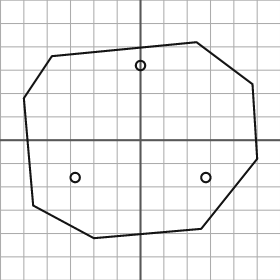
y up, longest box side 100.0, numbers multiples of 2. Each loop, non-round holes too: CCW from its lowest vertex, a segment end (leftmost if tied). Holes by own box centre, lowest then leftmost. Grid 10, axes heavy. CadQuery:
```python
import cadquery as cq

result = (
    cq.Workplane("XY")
    .moveTo(-20.0, -42.0)
    .lineTo(26.0, -38.0)
    .lineTo(50.0, -8.0)
    .lineTo(48.0, 24.0)
    .lineTo(24.0, 42.0)
    .lineTo(-38.0, 36.0)
    .lineTo(-50.0, 18.0)
    .lineTo(-46.0, -28.0)
    .close()
    .moveTo(-28.0, -16.0)
    .circle(2.0)
    .moveTo(28.0, -16.0)
    .circle(2.0)
    .moveTo(0.0, 32.0)
    .circle(2.0)
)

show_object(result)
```